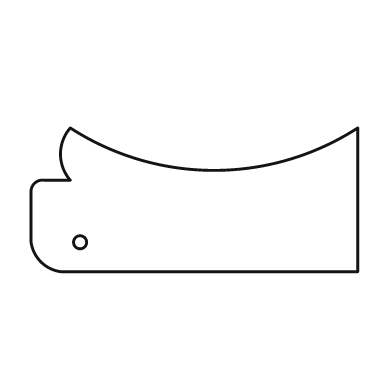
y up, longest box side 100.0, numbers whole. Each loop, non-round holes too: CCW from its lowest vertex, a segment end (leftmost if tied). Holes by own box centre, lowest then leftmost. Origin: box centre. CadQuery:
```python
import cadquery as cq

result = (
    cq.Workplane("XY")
    .moveTo(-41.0, -22.0)
    .lineTo(50.0, -22.0)
    .lineTo(50.0, 22.0)
    .threePointArc((6.0, 9.0), (-38.0, 22.0))
    .threePointArc((-41.0, 14.0), (-38.0, 6.0))
    .lineTo(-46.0, 6.0)
    .threePointArc((-49.0, 5.0), (-50.0, 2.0))
    .lineTo(-50.0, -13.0)
    .threePointArc((-47.0, -19.0), (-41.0, -22.0))
    .close()
    .moveTo(-35.0, -13.0)
    .circle(2.0)
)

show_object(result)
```